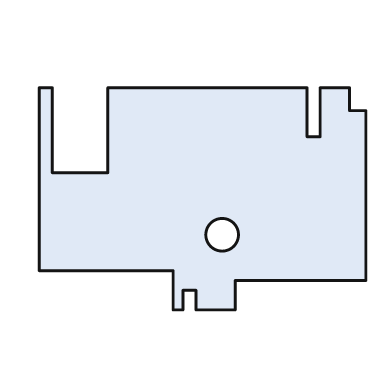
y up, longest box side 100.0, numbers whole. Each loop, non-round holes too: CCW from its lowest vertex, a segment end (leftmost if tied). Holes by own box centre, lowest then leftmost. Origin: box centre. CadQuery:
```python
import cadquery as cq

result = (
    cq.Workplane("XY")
    .moveTo(-9.0, -34.0)
    .lineTo(-6.0, -34.0)
    .lineTo(-6.0, -28.0)
    .lineTo(-2.0, -28.0)
    .lineTo(-2.0, -34.0)
    .lineTo(10.0, -34.0)
    .lineTo(10.0, -25.0)
    .lineTo(50.0, -25.0)
    .lineTo(50.0, 27.0)
    .lineTo(45.0, 27.0)
    .lineTo(45.0, 34.0)
    .lineTo(36.0, 34.0)
    .lineTo(36.0, 19.0)
    .lineTo(32.0, 19.0)
    .lineTo(32.0, 34.0)
    .lineTo(-29.0, 34.0)
    .lineTo(-29.0, 8.0)
    .lineTo(-46.0, 8.0)
    .lineTo(-46.0, 34.0)
    .lineTo(-50.0, 34.0)
    .lineTo(-50.0, -22.0)
    .lineTo(-9.0, -22.0)
    .close()
    .moveTo(6.0, -11.0)
    .circle(5.0)
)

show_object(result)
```